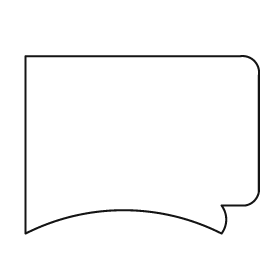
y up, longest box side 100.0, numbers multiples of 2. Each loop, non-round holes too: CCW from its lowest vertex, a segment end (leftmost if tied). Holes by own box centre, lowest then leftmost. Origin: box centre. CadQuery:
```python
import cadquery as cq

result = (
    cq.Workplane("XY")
    .moveTo(-50.0, -38.0)
    .threePointArc((-8.0, -28.0), (34.0, -38.0))
    .threePointArc((36.0, -32.0), (34.0, -26.0))
    .lineTo(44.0, -26.0)
    .threePointArc((48.0, -24.0), (50.0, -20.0))
    .lineTo(50.0, 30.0)
    .threePointArc((48.0, 36.0), (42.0, 38.0))
    .lineTo(-50.0, 38.0)
    .close()
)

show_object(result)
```